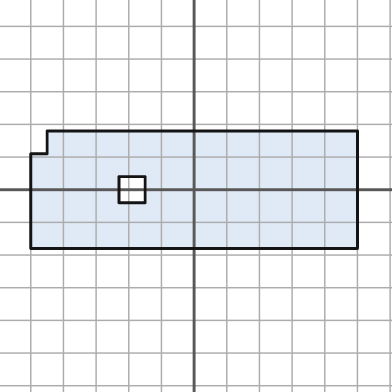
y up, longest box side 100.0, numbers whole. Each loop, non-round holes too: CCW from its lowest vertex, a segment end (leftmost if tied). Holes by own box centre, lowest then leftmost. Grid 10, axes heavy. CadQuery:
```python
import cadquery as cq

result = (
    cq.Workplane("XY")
    .moveTo(-50.0, -18.0)
    .lineTo(50.0, -18.0)
    .lineTo(50.0, 18.0)
    .lineTo(-45.0, 18.0)
    .lineTo(-45.0, 11.0)
    .lineTo(-50.0, 11.0)
    .close()
    .moveTo(-23.0, -4.0)
    .lineTo(-15.0, -4.0)
    .lineTo(-15.0, 4.0)
    .lineTo(-23.0, 4.0)
    .close()
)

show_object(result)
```